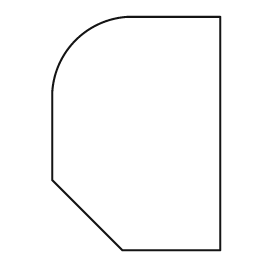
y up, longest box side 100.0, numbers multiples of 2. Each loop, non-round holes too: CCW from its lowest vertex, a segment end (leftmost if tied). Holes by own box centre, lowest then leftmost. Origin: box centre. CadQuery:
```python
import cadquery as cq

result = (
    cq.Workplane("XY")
    .moveTo(-6.0, -50.0)
    .lineTo(36.0, -50.0)
    .lineTo(36.0, 50.0)
    .lineTo(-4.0, 50.0)
    .threePointArc((-26.0, 40.0), (-36.0, 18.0))
    .lineTo(-36.0, -20.0)
    .close()
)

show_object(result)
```